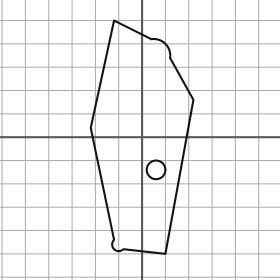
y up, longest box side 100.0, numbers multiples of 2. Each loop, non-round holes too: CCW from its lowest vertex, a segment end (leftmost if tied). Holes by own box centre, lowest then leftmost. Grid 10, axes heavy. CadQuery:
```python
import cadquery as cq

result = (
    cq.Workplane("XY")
    .moveTo(10.0, -50.0)
    .lineTo(22.0, 16.0)
    .lineTo(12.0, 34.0)
    .threePointArc((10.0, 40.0), (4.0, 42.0))
    .lineTo(-12.0, 50.0)
    .lineTo(-22.0, 4.0)
    .lineTo(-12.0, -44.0)
    .threePointArc((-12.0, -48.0), (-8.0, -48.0))
    .close()
    .moveTo(6.0, -14.0)
    .circle(4.0)
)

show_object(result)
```